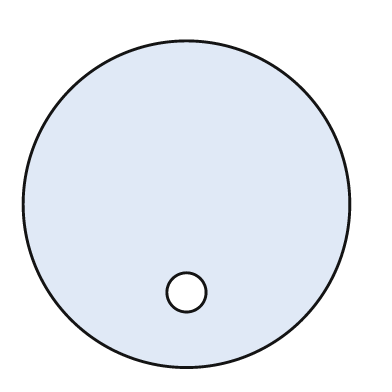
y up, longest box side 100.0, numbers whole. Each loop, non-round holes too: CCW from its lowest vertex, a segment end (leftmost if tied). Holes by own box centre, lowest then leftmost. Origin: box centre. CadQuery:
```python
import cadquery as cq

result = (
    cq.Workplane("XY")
    .moveTo(0.0, 0.0)
    .circle(50.0)
    .moveTo(0.0, -27.0)
    .circle(6.0)
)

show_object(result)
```